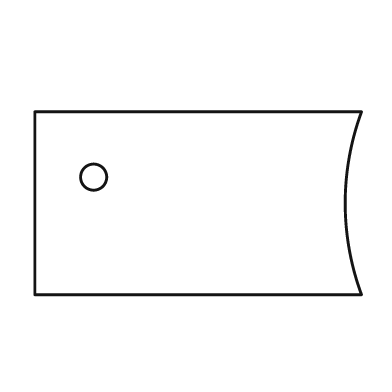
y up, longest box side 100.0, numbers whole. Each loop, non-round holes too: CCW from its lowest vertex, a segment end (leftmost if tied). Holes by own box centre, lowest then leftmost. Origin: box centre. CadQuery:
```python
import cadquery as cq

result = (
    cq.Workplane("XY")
    .moveTo(-50.0, -28.0)
    .lineTo(50.0, -28.0)
    .threePointArc((45.0, 0.0), (50.0, 28.0))
    .lineTo(-50.0, 28.0)
    .close()
    .moveTo(-32.0, 8.0)
    .circle(4.0)
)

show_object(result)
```